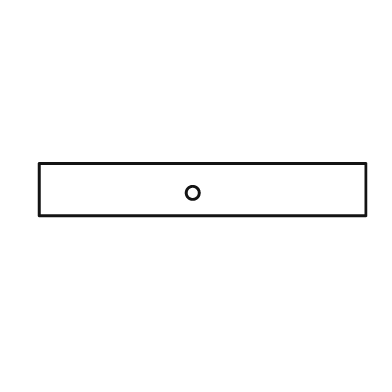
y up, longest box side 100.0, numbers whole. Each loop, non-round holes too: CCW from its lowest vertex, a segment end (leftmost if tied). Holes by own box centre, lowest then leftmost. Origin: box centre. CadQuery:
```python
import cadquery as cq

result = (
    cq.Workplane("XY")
    .moveTo(-50.0, -8.0)
    .lineTo(50.0, -8.0)
    .lineTo(50.0, 8.0)
    .lineTo(-50.0, 8.0)
    .close()
    .moveTo(-3.0, -1.0)
    .circle(2.0)
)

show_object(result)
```